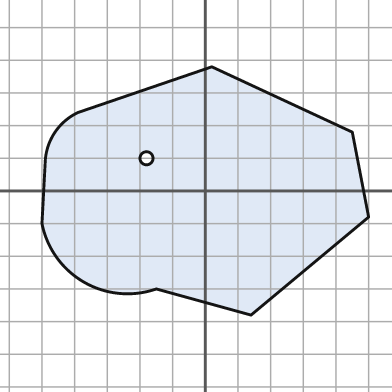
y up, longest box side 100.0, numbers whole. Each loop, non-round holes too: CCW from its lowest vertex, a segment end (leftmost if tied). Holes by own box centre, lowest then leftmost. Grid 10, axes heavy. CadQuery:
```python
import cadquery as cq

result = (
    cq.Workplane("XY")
    .moveTo(14.0, -38.0)
    .lineTo(50.0, -8.0)
    .lineTo(45.0, 18.0)
    .lineTo(2.0, 38.0)
    .lineTo(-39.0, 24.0)
    .threePointArc((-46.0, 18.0), (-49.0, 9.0))
    .lineTo(-50.0, -10.0)
    .threePointArc((-37.0, -28.0), (-15.0, -30.0))
    .close()
    .moveTo(-18.0, 10.0)
    .circle(2.0)
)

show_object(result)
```